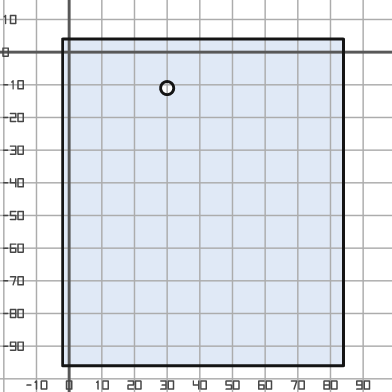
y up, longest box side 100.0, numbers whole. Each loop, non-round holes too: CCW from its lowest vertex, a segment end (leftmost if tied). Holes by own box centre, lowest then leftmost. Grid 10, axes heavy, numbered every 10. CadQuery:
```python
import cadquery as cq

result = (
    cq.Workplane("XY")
    .moveTo(-2.0, -96.0)
    .lineTo(84.0, -96.0)
    .lineTo(84.0, 4.0)
    .lineTo(-2.0, 4.0)
    .close()
    .moveTo(30.0, -11.0)
    .circle(2.0)
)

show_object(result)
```